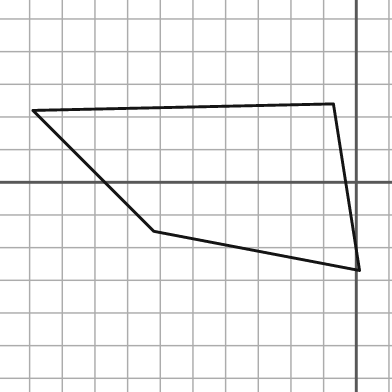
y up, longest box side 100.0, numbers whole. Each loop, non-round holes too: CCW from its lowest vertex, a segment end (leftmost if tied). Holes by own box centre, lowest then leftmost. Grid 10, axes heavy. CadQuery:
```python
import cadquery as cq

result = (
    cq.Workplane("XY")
    .moveTo(1.0, -27.0)
    .lineTo(-7.0, 24.0)
    .lineTo(-99.0, 22.0)
    .lineTo(-62.0, -15.0)
    .close()
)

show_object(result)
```